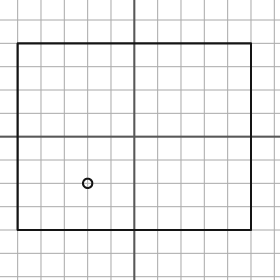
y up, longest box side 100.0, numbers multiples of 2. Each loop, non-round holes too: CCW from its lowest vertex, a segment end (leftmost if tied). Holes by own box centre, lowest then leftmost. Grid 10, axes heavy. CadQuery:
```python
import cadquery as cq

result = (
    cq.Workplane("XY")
    .moveTo(-50.0, -40.0)
    .lineTo(50.0, -40.0)
    .lineTo(50.0, 40.0)
    .lineTo(-50.0, 40.0)
    .close()
    .moveTo(-20.0, -20.0)
    .circle(2.0)
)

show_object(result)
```